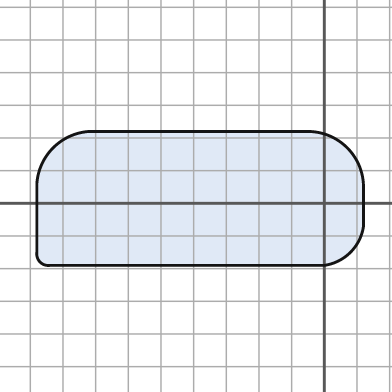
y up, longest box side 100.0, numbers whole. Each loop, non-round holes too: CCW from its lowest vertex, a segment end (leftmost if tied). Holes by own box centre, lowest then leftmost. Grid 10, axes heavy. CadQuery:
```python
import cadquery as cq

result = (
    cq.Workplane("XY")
    .moveTo(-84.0, -19.0)
    .lineTo(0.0, -19.0)
    .threePointArc((8.0, -15.0), (12.0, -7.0))
    .lineTo(12.0, 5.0)
    .threePointArc((7.0, 17.0), (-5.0, 22.0))
    .lineTo(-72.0, 22.0)
    .threePointArc((-83.0, 17.0), (-88.0, 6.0))
    .lineTo(-88.0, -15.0)
    .threePointArc((-87.0, -18.0), (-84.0, -19.0))
    .close()
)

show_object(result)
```